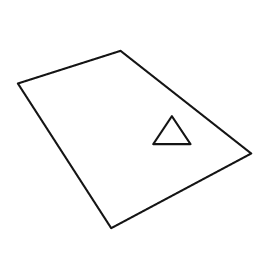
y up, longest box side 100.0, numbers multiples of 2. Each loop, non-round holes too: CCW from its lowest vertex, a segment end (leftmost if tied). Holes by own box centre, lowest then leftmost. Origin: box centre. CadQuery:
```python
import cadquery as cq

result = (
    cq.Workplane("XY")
    .moveTo(-10.0, -38.0)
    .lineTo(50.0, -6.0)
    .lineTo(-6.0, 38.0)
    .lineTo(-50.0, 24.0)
    .close()
    .moveTo(8.0, -2.0)
    .lineTo(24.0, -2.0)
    .lineTo(16.0, 10.0)
    .close()
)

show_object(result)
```